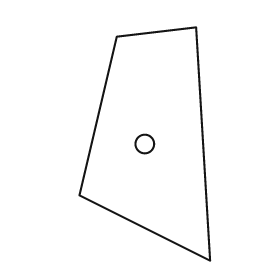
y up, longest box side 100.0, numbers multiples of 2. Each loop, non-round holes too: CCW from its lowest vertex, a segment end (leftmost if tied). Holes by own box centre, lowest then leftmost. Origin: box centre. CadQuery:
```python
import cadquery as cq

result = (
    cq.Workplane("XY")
    .moveTo(28.0, -50.0)
    .lineTo(22.0, 50.0)
    .lineTo(-12.0, 46.0)
    .lineTo(-28.0, -22.0)
    .close()
    .moveTo(0.0, 0.0)
    .circle(4.0)
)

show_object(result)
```